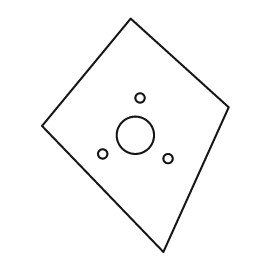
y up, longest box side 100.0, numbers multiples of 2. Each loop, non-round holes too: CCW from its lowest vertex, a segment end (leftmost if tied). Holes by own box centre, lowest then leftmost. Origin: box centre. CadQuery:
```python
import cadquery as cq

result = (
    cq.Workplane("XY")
    .moveTo(12.0, -50.0)
    .lineTo(40.0, 12.0)
    .lineTo(-2.0, 50.0)
    .lineTo(-40.0, 4.0)
    .close()
    .moveTo(14.0, -10.0)
    .circle(2.0)
    .moveTo(-14.0, -8.0)
    .circle(2.0)
    .moveTo(0.0, 0.0)
    .circle(8.0)
    .moveTo(2.0, 16.0)
    .circle(2.0)
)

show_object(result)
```